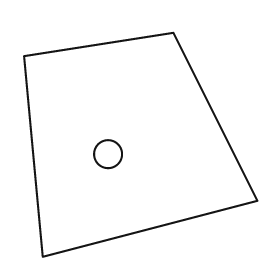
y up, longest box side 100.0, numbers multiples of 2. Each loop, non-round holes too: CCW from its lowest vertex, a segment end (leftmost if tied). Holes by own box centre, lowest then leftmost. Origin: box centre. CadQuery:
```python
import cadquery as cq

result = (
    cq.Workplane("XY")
    .moveTo(-42.0, -48.0)
    .lineTo(50.0, -24.0)
    .lineTo(14.0, 48.0)
    .lineTo(-50.0, 38.0)
    .close()
    .moveTo(-14.0, -4.0)
    .circle(6.0)
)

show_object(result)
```